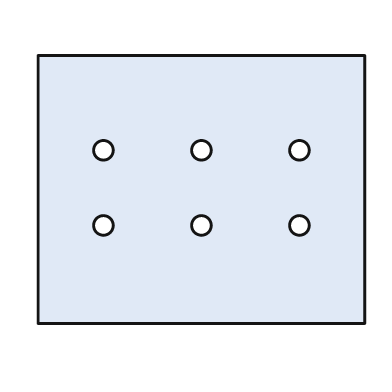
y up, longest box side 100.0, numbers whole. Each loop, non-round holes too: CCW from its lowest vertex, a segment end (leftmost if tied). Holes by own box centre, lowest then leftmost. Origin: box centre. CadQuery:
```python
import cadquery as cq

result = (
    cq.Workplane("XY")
    .moveTo(-50.0, -41.0)
    .lineTo(50.0, -41.0)
    .lineTo(50.0, 41.0)
    .lineTo(-50.0, 41.0)
    .close()
    .moveTo(-30.0, -11.0)
    .circle(3.0)
    .moveTo(0.0, -11.0)
    .circle(3.0)
    .moveTo(30.0, -11.0)
    .circle(3.0)
    .moveTo(-30.0, 12.0)
    .circle(3.0)
    .moveTo(0.0, 12.0)
    .circle(3.0)
    .moveTo(30.0, 12.0)
    .circle(3.0)
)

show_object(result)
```